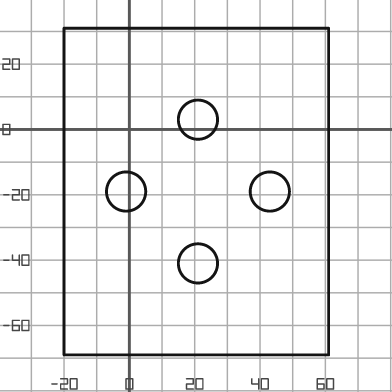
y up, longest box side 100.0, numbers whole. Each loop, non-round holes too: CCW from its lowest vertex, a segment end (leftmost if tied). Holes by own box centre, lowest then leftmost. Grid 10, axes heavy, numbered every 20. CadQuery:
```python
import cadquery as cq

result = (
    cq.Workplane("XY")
    .moveTo(-20.0, -69.0)
    .lineTo(61.0, -69.0)
    .lineTo(61.0, 31.0)
    .lineTo(-20.0, 31.0)
    .close()
    .moveTo(21.0, -41.0)
    .circle(6.0)
    .moveTo(-1.0, -19.0)
    .circle(6.0)
    .moveTo(43.0, -19.0)
    .circle(6.0)
    .moveTo(21.0, 3.0)
    .circle(6.0)
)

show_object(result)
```